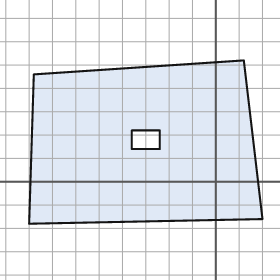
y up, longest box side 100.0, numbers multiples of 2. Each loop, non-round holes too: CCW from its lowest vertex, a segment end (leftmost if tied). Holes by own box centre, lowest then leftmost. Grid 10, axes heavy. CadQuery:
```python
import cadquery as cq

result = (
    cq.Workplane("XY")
    .moveTo(-80.0, -18.0)
    .lineTo(20.0, -16.0)
    .lineTo(12.0, 52.0)
    .lineTo(-78.0, 46.0)
    .close()
    .moveTo(-36.0, 14.0)
    .lineTo(-24.0, 14.0)
    .lineTo(-24.0, 22.0)
    .lineTo(-36.0, 22.0)
    .close()
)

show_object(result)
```